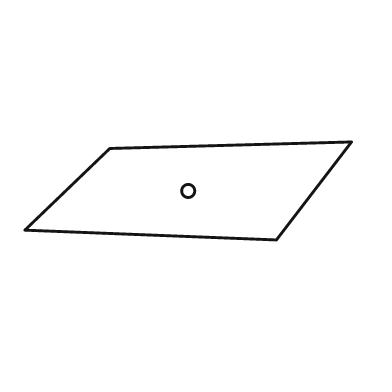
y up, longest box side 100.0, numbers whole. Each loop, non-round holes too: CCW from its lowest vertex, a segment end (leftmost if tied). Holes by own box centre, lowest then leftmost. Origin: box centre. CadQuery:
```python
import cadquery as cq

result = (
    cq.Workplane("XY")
    .moveTo(27.0, -15.0)
    .lineTo(50.0, 15.0)
    .lineTo(-24.0, 13.0)
    .lineTo(-50.0, -12.0)
    .close()
    .moveTo(0.0, 0.0)
    .circle(2.0)
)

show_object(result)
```